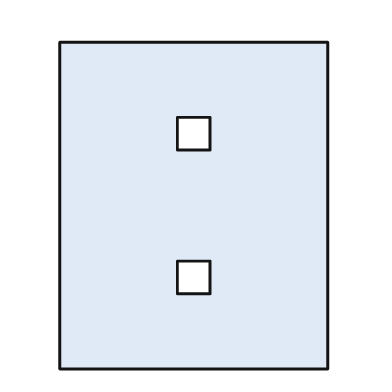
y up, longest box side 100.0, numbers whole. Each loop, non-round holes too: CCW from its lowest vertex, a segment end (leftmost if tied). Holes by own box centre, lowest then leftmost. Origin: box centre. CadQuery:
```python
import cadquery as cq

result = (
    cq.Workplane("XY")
    .moveTo(-41.0, -50.0)
    .lineTo(41.0, -50.0)
    .lineTo(41.0, 50.0)
    .lineTo(-41.0, 50.0)
    .close()
    .moveTo(-5.0, -27.0)
    .lineTo(5.0, -27.0)
    .lineTo(5.0, -17.0)
    .lineTo(-5.0, -17.0)
    .close()
    .moveTo(-5.0, 17.0)
    .lineTo(5.0, 17.0)
    .lineTo(5.0, 27.0)
    .lineTo(-5.0, 27.0)
    .close()
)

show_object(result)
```